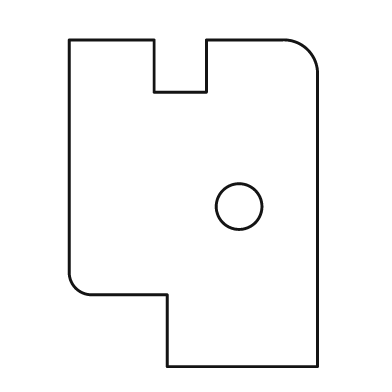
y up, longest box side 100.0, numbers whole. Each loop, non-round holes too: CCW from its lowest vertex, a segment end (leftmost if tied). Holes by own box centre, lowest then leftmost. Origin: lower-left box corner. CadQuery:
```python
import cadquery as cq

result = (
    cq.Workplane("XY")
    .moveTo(30.0, 0.0)
    .lineTo(76.0, 0.0)
    .lineTo(76.0, 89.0)
    .threePointArc((73.0, 97.0), (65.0, 100.0))
    .lineTo(42.0, 100.0)
    .lineTo(42.0, 84.0)
    .lineTo(26.0, 84.0)
    .lineTo(26.0, 100.0)
    .lineTo(0.0, 100.0)
    .lineTo(0.0, 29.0)
    .threePointArc((2.0, 24.0), (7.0, 22.0))
    .lineTo(30.0, 22.0)
    .close()
    .moveTo(52.0, 49.0)
    .circle(7.0)
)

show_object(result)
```